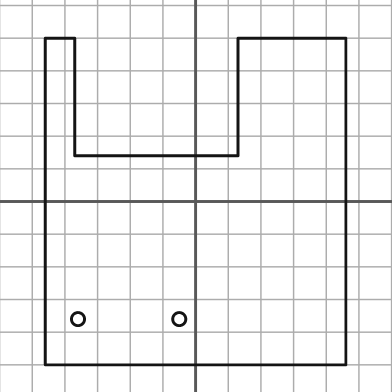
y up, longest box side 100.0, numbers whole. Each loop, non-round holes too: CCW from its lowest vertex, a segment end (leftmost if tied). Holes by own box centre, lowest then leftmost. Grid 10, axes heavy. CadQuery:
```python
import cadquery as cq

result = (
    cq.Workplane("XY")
    .moveTo(-46.0, -50.0)
    .lineTo(46.0, -50.0)
    .lineTo(46.0, 50.0)
    .lineTo(13.0, 50.0)
    .lineTo(13.0, 14.0)
    .lineTo(-37.0, 14.0)
    .lineTo(-37.0, 50.0)
    .lineTo(-46.0, 50.0)
    .close()
    .moveTo(-36.0, -36.0)
    .circle(2.0)
    .moveTo(-5.0, -36.0)
    .circle(2.0)
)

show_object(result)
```